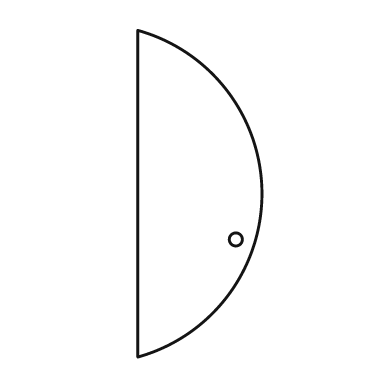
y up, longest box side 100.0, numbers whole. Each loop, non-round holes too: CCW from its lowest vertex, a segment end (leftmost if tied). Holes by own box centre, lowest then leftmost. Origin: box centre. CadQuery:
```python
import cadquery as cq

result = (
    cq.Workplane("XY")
    .moveTo(-19.0, -50.0)
    .threePointArc((19.0, 0.0), (-19.0, 50.0))
    .close()
    .moveTo(11.0, -14.0)
    .circle(2.0)
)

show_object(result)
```